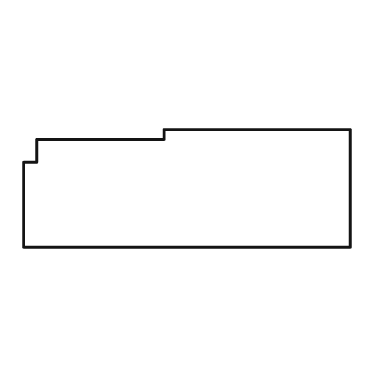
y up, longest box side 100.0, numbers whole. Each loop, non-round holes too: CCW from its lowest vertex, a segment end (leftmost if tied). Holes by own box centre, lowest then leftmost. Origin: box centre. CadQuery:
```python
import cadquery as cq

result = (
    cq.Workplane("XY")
    .moveTo(-50.0, -18.0)
    .lineTo(50.0, -18.0)
    .lineTo(50.0, 18.0)
    .lineTo(-7.0, 18.0)
    .lineTo(-7.0, 15.0)
    .lineTo(-46.0, 15.0)
    .lineTo(-46.0, 8.0)
    .lineTo(-50.0, 8.0)
    .close()
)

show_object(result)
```